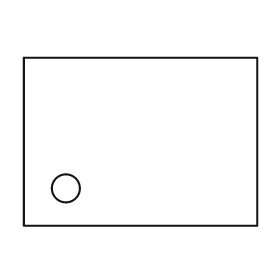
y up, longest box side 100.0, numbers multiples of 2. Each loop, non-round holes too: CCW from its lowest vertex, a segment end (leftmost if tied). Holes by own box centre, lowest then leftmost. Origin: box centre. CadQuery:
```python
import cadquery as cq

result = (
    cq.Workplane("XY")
    .moveTo(-50.0, -36.0)
    .lineTo(50.0, -36.0)
    .lineTo(50.0, 36.0)
    .lineTo(-50.0, 36.0)
    .close()
    .moveTo(-32.0, -20.0)
    .circle(6.0)
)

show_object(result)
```